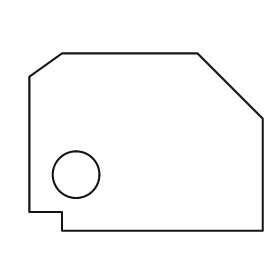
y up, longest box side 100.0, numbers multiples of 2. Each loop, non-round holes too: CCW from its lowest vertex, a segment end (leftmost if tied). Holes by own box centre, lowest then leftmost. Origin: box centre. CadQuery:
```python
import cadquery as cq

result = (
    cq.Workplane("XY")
    .moveTo(-36.0, -38.0)
    .lineTo(50.0, -38.0)
    .lineTo(50.0, 10.0)
    .lineTo(22.0, 38.0)
    .lineTo(-36.0, 38.0)
    .lineTo(-50.0, 28.0)
    .lineTo(-50.0, -30.0)
    .lineTo(-36.0, -30.0)
    .close()
    .moveTo(-30.0, -14.0)
    .circle(10.0)
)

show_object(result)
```